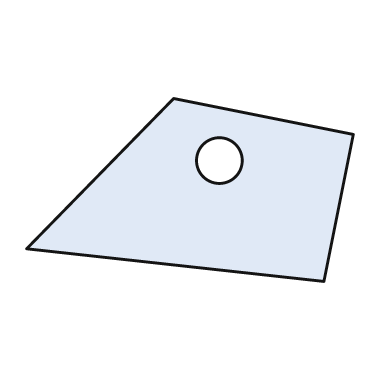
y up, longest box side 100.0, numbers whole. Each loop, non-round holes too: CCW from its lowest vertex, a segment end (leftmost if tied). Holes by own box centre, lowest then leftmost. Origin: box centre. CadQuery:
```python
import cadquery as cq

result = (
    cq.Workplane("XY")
    .moveTo(41.0, -28.0)
    .lineTo(50.0, 17.0)
    .lineTo(-5.0, 28.0)
    .lineTo(-50.0, -18.0)
    .close()
    .moveTo(9.0, 9.0)
    .circle(7.0)
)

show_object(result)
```